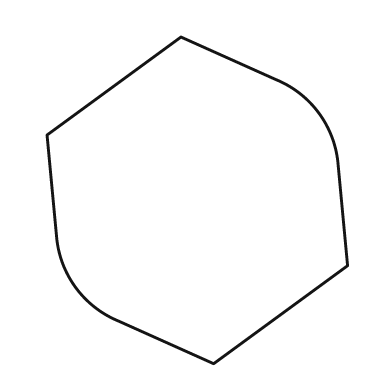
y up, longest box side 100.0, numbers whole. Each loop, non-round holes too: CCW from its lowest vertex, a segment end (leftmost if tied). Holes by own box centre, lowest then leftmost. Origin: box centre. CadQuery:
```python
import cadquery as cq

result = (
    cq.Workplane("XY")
    .moveTo(5.0, -50.0)
    .lineTo(46.0, -20.0)
    .lineTo(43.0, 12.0)
    .threePointArc((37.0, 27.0), (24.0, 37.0))
    .lineTo(-5.0, 50.0)
    .lineTo(-46.0, 20.0)
    .lineTo(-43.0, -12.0)
    .threePointArc((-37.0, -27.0), (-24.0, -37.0))
    .close()
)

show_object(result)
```